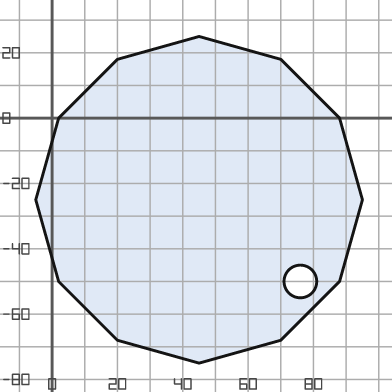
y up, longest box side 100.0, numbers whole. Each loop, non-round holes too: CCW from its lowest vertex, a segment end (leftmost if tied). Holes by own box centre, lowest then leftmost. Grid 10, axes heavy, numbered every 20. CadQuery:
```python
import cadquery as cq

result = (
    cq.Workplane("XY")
    .moveTo(45.0, -75.0)
    .lineTo(70.0, -68.0)
    .lineTo(88.0, -50.0)
    .lineTo(95.0, -25.0)
    .lineTo(88.0, 0.0)
    .lineTo(70.0, 18.0)
    .lineTo(45.0, 25.0)
    .lineTo(20.0, 18.0)
    .lineTo(2.0, 0.0)
    .lineTo(-5.0, -25.0)
    .lineTo(2.0, -50.0)
    .lineTo(20.0, -68.0)
    .close()
    .moveTo(76.0, -50.0)
    .circle(5.0)
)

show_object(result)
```